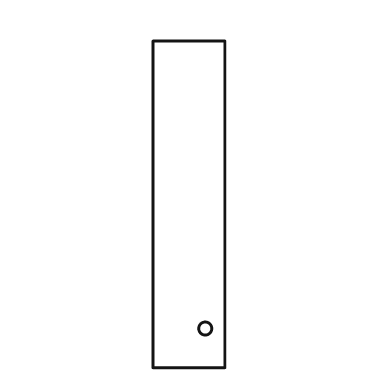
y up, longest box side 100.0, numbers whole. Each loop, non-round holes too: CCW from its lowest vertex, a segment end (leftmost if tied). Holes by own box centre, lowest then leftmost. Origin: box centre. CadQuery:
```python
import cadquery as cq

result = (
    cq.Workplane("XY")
    .moveTo(-11.0, -50.0)
    .lineTo(11.0, -50.0)
    .lineTo(11.0, 50.0)
    .lineTo(-11.0, 50.0)
    .close()
    .moveTo(5.0, -38.0)
    .circle(2.0)
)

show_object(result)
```